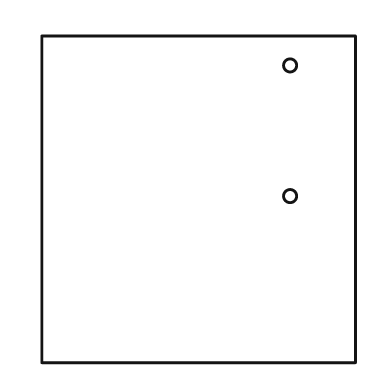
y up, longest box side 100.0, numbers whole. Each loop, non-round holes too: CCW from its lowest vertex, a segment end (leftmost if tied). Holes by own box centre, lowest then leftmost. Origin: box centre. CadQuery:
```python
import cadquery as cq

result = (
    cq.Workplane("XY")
    .moveTo(-48.0, -50.0)
    .lineTo(48.0, -50.0)
    .lineTo(48.0, 50.0)
    .lineTo(-48.0, 50.0)
    .close()
    .moveTo(28.0, 1.0)
    .circle(2.0)
    .moveTo(28.0, 41.0)
    .circle(2.0)
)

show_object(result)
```